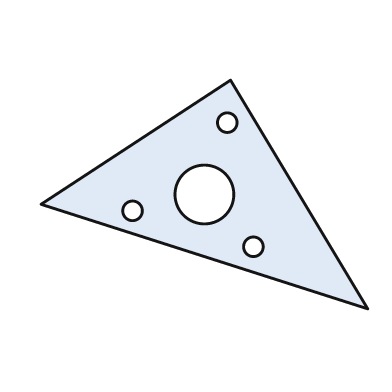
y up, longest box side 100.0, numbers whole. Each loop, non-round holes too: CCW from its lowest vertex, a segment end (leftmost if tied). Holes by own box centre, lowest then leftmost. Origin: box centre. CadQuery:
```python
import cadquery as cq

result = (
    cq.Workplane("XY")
    .moveTo(50.0, -35.0)
    .lineTo(8.0, 35.0)
    .lineTo(-50.0, -3.0)
    .close()
    .moveTo(15.0, -16.0)
    .circle(3.0)
    .moveTo(-22.0, -5.0)
    .circle(3.0)
    .moveTo(0.0, 0.0)
    .circle(9.0)
    .moveTo(7.0, 22.0)
    .circle(3.0)
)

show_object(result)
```